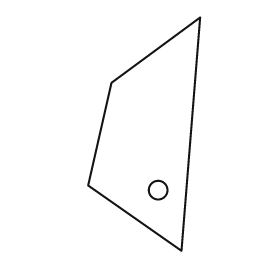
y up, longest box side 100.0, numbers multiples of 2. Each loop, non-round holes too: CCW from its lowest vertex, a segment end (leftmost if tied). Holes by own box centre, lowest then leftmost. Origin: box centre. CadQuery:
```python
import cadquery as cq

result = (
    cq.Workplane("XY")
    .moveTo(16.0, -50.0)
    .lineTo(24.0, 50.0)
    .lineTo(-14.0, 22.0)
    .lineTo(-24.0, -22.0)
    .close()
    .moveTo(6.0, -24.0)
    .circle(4.0)
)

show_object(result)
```